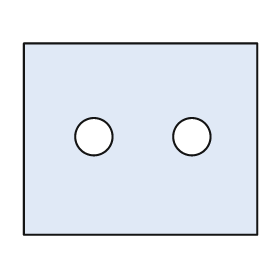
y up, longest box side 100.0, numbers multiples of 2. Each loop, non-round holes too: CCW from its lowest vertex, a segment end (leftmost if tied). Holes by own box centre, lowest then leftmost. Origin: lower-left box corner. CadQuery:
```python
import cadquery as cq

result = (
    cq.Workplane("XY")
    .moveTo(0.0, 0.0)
    .lineTo(100.0, 0.0)
    .lineTo(100.0, 82.0)
    .lineTo(0.0, 82.0)
    .close()
    .moveTo(30.0, 42.0)
    .circle(8.0)
    .moveTo(72.0, 42.0)
    .circle(8.0)
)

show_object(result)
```